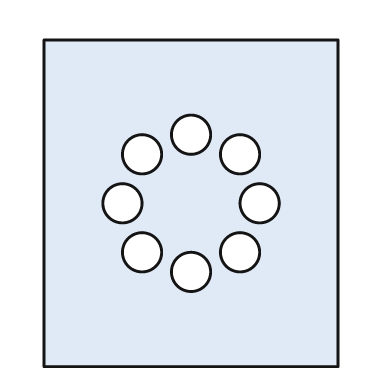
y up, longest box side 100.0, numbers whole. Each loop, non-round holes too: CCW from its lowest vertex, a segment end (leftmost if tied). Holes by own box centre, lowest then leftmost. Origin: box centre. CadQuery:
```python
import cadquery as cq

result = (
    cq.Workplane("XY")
    .moveTo(-45.0, -50.0)
    .lineTo(45.0, -50.0)
    .lineTo(45.0, 50.0)
    .lineTo(-45.0, 50.0)
    .close()
    .moveTo(0.0, -21.0)
    .circle(6.0)
    .moveTo(-15.0, -15.0)
    .circle(6.0)
    .moveTo(15.0, -15.0)
    .circle(6.0)
    .moveTo(-21.0, 0.0)
    .circle(6.0)
    .moveTo(21.0, 0.0)
    .circle(6.0)
    .moveTo(-15.0, 15.0)
    .circle(6.0)
    .moveTo(15.0, 15.0)
    .circle(6.0)
    .moveTo(0.0, 21.0)
    .circle(6.0)
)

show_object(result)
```